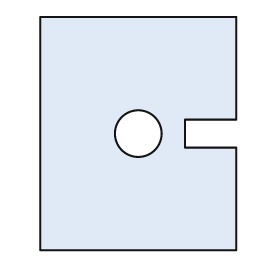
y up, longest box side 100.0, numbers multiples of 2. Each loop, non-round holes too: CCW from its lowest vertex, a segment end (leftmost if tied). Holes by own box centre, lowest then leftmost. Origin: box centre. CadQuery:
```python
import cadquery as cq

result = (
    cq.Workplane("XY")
    .moveTo(-42.0, -50.0)
    .lineTo(42.0, -50.0)
    .lineTo(42.0, -6.0)
    .lineTo(20.0, -6.0)
    .lineTo(20.0, 6.0)
    .lineTo(42.0, 6.0)
    .lineTo(42.0, 50.0)
    .lineTo(-42.0, 50.0)
    .close()
    .moveTo(0.0, 0.0)
    .circle(10.0)
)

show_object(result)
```